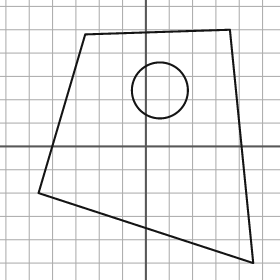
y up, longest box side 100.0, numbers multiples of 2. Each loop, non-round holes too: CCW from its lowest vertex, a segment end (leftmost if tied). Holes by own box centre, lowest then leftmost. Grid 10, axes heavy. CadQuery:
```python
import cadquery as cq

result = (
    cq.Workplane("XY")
    .moveTo(46.0, -50.0)
    .lineTo(36.0, 50.0)
    .lineTo(-26.0, 48.0)
    .lineTo(-46.0, -20.0)
    .close()
    .moveTo(6.0, 24.0)
    .circle(12.0)
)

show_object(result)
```